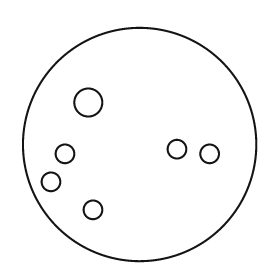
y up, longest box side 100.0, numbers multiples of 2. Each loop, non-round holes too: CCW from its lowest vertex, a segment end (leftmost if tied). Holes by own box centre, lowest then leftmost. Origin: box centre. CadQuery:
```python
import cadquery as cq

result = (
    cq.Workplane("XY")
    .moveTo(0.0, 0.0)
    .circle(50.0)
    .moveTo(-20.0, -28.0)
    .circle(4.0)
    .moveTo(-38.0, -16.0)
    .circle(4.0)
    .moveTo(-32.0, -4.0)
    .circle(4.0)
    .moveTo(30.0, -4.0)
    .circle(4.0)
    .moveTo(16.0, -2.0)
    .circle(4.0)
    .moveTo(-22.0, 18.0)
    .circle(6.0)
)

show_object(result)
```